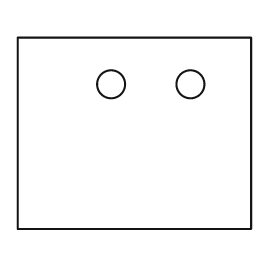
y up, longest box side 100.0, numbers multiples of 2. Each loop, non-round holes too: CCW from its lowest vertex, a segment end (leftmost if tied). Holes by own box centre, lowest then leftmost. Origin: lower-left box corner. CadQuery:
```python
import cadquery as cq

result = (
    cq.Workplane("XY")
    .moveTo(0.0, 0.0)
    .lineTo(100.0, 0.0)
    .lineTo(100.0, 82.0)
    .lineTo(0.0, 82.0)
    .close()
    .moveTo(40.0, 62.0)
    .circle(6.0)
    .moveTo(74.0, 62.0)
    .circle(6.0)
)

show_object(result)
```